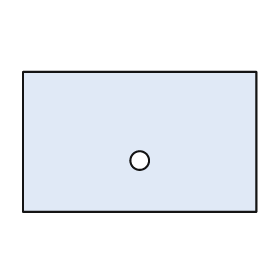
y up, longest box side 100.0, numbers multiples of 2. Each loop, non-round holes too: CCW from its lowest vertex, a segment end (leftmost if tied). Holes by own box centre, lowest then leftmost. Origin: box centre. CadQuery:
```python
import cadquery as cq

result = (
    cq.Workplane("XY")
    .moveTo(-50.0, -30.0)
    .lineTo(50.0, -30.0)
    .lineTo(50.0, 30.0)
    .lineTo(-50.0, 30.0)
    .close()
    .moveTo(0.0, -8.0)
    .circle(4.0)
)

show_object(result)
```